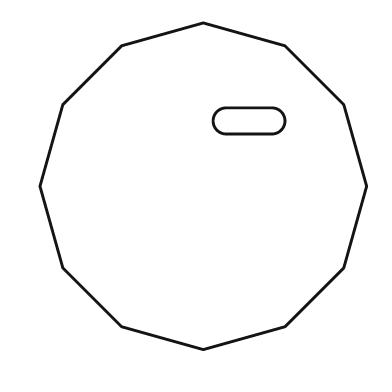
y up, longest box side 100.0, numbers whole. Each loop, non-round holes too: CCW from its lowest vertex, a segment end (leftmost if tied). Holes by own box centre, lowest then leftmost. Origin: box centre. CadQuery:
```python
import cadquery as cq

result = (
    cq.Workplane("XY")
    .moveTo(0.0, -50.0)
    .lineTo(25.0, -43.0)
    .lineTo(43.0, -25.0)
    .lineTo(50.0, 0.0)
    .lineTo(43.0, 25.0)
    .lineTo(25.0, 43.0)
    .lineTo(0.0, 50.0)
    .lineTo(-25.0, 43.0)
    .lineTo(-43.0, 25.0)
    .lineTo(-50.0, 0.0)
    .lineTo(-43.0, -25.0)
    .lineTo(-25.0, -43.0)
    .close()
    .moveTo(7.0, 16.0)
    .lineTo(21.0, 16.0)
    .threePointArc((25.0, 20.0), (21.0, 24.0))
    .lineTo(7.0, 24.0)
    .threePointArc((3.0, 20.0), (7.0, 16.0))
    .close()
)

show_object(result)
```